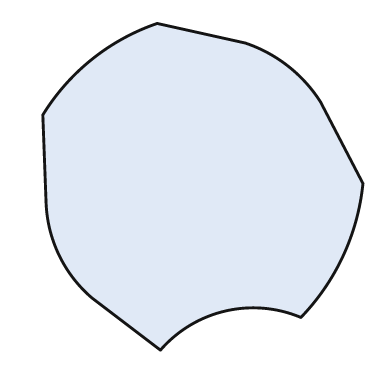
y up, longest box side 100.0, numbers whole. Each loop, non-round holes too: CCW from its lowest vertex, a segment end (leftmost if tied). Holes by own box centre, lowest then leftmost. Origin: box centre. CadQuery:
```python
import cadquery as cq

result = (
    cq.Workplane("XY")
    .moveTo(-13.0, -50.0)
    .threePointArc((7.0, -38.0), (30.0, -40.0))
    .threePointArc((43.0, -21.0), (49.0, 1.0))
    .lineTo(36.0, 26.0)
    .threePointArc((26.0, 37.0), (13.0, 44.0))
    .lineTo(-14.0, 50.0)
    .threePointArc((-34.0, 39.0), (-49.0, 22.0))
    .lineTo(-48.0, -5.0)
    .threePointArc((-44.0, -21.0), (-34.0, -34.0))
    .close()
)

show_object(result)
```